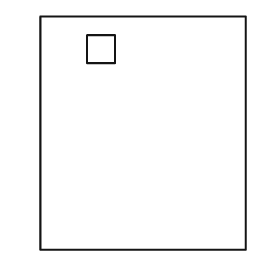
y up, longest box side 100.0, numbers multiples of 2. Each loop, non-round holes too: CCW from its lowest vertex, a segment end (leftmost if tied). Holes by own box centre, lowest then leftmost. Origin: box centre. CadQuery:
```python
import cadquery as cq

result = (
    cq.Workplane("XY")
    .moveTo(-44.0, -50.0)
    .lineTo(44.0, -50.0)
    .lineTo(44.0, 50.0)
    .lineTo(-44.0, 50.0)
    .close()
    .moveTo(-24.0, 30.0)
    .lineTo(-12.0, 30.0)
    .lineTo(-12.0, 42.0)
    .lineTo(-24.0, 42.0)
    .close()
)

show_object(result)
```